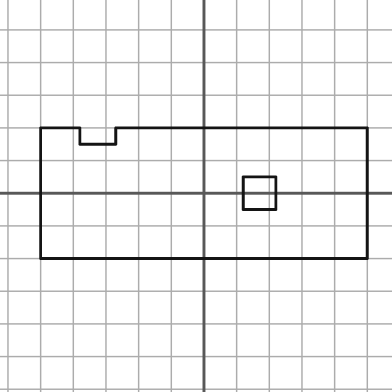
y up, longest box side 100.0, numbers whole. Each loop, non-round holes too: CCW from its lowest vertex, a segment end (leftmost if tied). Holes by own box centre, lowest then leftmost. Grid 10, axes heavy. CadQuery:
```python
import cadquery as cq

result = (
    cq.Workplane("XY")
    .moveTo(-50.0, -20.0)
    .lineTo(50.0, -20.0)
    .lineTo(50.0, 20.0)
    .lineTo(-27.0, 20.0)
    .lineTo(-27.0, 15.0)
    .lineTo(-38.0, 15.0)
    .lineTo(-38.0, 20.0)
    .lineTo(-50.0, 20.0)
    .close()
    .moveTo(12.0, -5.0)
    .lineTo(22.0, -5.0)
    .lineTo(22.0, 5.0)
    .lineTo(12.0, 5.0)
    .close()
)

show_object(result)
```